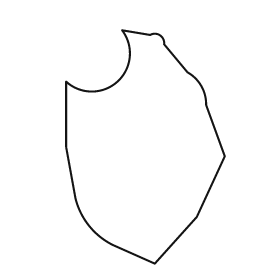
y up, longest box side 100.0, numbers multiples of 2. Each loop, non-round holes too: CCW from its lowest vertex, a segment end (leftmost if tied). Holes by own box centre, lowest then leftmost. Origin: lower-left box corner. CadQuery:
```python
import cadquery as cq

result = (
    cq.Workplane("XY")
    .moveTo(38.0, 0.0)
    .lineTo(56.0, 20.0)
    .lineTo(68.0, 46.0)
    .lineTo(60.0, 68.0)
    .threePointArc((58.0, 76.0), (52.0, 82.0))
    .lineTo(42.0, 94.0)
    .threePointArc((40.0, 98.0), (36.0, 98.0))
    .lineTo(24.0, 100.0)
    .threePointArc((22.0, 78.0), (0.0, 78.0))
    .lineTo(0.0, 50.0)
    .lineTo(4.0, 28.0)
    .threePointArc((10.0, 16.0), (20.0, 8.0))
    .close()
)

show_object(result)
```